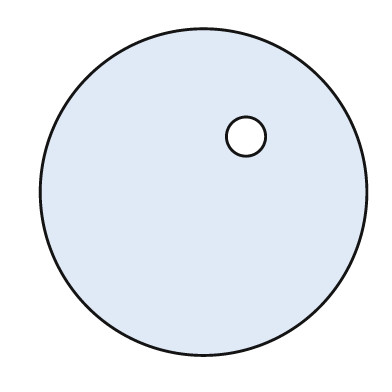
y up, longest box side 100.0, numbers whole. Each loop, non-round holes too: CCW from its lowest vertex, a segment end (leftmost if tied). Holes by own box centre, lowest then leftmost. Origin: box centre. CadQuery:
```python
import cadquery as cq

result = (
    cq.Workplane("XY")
    .moveTo(0.0, 0.0)
    .circle(50.0)
    .moveTo(13.0, 17.0)
    .circle(6.0)
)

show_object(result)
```